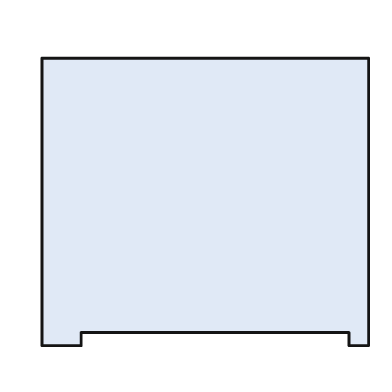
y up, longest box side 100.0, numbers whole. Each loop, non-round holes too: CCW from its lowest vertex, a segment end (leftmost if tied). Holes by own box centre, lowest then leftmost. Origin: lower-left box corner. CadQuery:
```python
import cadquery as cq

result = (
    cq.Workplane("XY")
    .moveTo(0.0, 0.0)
    .lineTo(12.0, 0.0)
    .lineTo(12.0, 4.0)
    .lineTo(94.0, 4.0)
    .lineTo(94.0, 0.0)
    .lineTo(100.0, 0.0)
    .lineTo(100.0, 88.0)
    .lineTo(0.0, 88.0)
    .close()
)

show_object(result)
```